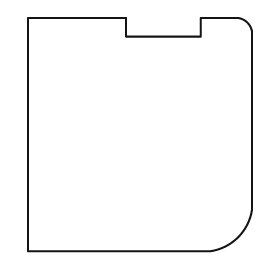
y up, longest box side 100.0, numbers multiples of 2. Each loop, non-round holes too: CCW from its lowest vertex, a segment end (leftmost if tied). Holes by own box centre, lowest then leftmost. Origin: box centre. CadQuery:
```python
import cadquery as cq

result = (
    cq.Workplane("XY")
    .moveTo(-48.0, -50.0)
    .lineTo(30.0, -50.0)
    .threePointArc((42.0, -44.0), (48.0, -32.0))
    .lineTo(48.0, 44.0)
    .threePointArc((46.0, 48.0), (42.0, 50.0))
    .lineTo(26.0, 50.0)
    .lineTo(26.0, 42.0)
    .lineTo(-6.0, 42.0)
    .lineTo(-6.0, 50.0)
    .lineTo(-48.0, 50.0)
    .close()
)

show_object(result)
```